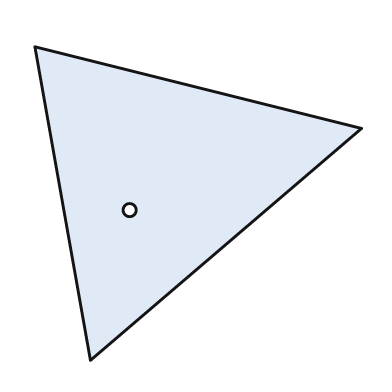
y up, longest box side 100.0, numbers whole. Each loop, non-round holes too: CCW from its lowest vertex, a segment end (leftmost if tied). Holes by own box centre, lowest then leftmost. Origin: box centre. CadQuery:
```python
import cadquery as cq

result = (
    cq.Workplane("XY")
    .moveTo(-33.0, -48.0)
    .lineTo(50.0, 23.0)
    .lineTo(-50.0, 48.0)
    .close()
    .moveTo(-21.0, -2.0)
    .circle(2.0)
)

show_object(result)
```